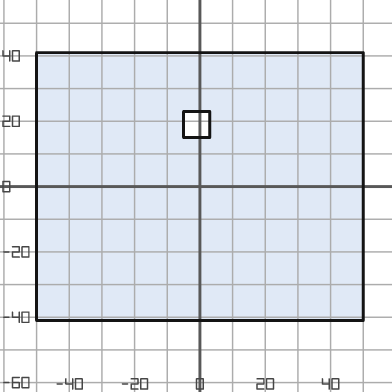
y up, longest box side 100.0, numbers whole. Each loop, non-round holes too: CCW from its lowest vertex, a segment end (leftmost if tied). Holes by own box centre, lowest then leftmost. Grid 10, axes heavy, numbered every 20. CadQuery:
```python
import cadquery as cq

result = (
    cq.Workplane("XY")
    .moveTo(-50.0, -41.0)
    .lineTo(50.0, -41.0)
    .lineTo(50.0, 41.0)
    .lineTo(-50.0, 41.0)
    .close()
    .moveTo(-5.0, 15.0)
    .lineTo(3.0, 15.0)
    .lineTo(3.0, 23.0)
    .lineTo(-5.0, 23.0)
    .close()
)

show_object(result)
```